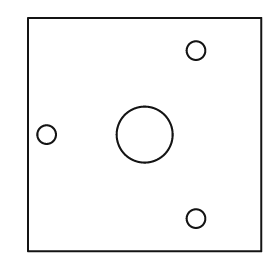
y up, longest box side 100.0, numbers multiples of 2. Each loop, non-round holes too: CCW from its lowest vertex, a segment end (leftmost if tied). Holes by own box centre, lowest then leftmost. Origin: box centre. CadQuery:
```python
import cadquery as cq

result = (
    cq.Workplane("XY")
    .moveTo(-50.0, -50.0)
    .lineTo(50.0, -50.0)
    .lineTo(50.0, 50.0)
    .lineTo(-50.0, 50.0)
    .close()
    .moveTo(22.0, -36.0)
    .circle(4.0)
    .moveTo(-42.0, 0.0)
    .circle(4.0)
    .moveTo(0.0, 0.0)
    .circle(12.0)
    .moveTo(22.0, 36.0)
    .circle(4.0)
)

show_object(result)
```